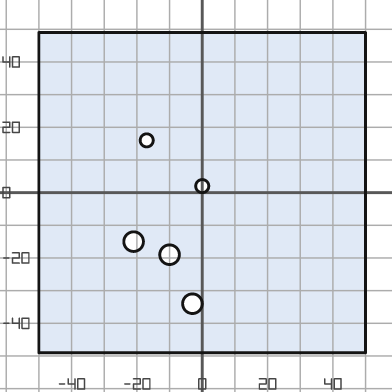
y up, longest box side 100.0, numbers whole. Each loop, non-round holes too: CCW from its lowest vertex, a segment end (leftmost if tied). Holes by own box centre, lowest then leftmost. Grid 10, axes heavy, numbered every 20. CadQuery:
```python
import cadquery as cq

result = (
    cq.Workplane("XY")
    .moveTo(-50.0, -49.0)
    .lineTo(50.0, -49.0)
    .lineTo(50.0, 49.0)
    .lineTo(-50.0, 49.0)
    .close()
    .moveTo(-3.0, -34.0)
    .circle(3.0)
    .moveTo(-10.0, -19.0)
    .circle(3.0)
    .moveTo(-21.0, -15.0)
    .circle(3.0)
    .moveTo(0.0, 2.0)
    .circle(2.0)
    .moveTo(-17.0, 16.0)
    .circle(2.0)
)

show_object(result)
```